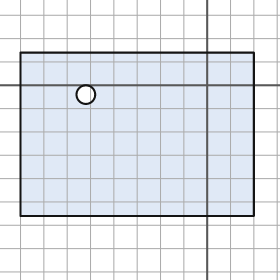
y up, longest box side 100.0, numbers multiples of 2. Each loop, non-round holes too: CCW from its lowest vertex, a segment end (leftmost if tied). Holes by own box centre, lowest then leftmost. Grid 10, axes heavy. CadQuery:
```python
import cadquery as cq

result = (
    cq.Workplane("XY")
    .moveTo(-80.0, -56.0)
    .lineTo(20.0, -56.0)
    .lineTo(20.0, 14.0)
    .lineTo(-80.0, 14.0)
    .close()
    .moveTo(-52.0, -4.0)
    .circle(4.0)
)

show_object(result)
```